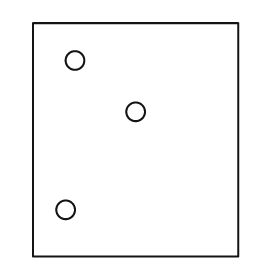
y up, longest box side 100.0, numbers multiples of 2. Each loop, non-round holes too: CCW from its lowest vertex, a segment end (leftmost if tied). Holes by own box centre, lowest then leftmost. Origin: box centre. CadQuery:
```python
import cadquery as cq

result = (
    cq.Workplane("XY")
    .moveTo(-44.0, -50.0)
    .lineTo(44.0, -50.0)
    .lineTo(44.0, 50.0)
    .lineTo(-44.0, 50.0)
    .close()
    .moveTo(-30.0, -30.0)
    .circle(4.0)
    .moveTo(0.0, 12.0)
    .circle(4.0)
    .moveTo(-26.0, 34.0)
    .circle(4.0)
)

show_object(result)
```